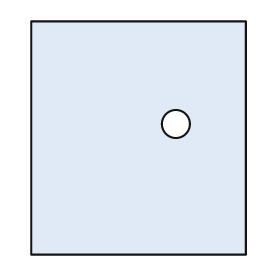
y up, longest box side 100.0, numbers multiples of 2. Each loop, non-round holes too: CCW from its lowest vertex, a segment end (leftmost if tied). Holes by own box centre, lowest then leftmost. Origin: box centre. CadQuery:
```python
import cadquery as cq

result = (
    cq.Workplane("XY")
    .moveTo(-46.0, -50.0)
    .lineTo(46.0, -50.0)
    .lineTo(46.0, 50.0)
    .lineTo(-46.0, 50.0)
    .close()
    .moveTo(16.0, 6.0)
    .circle(6.0)
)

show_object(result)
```